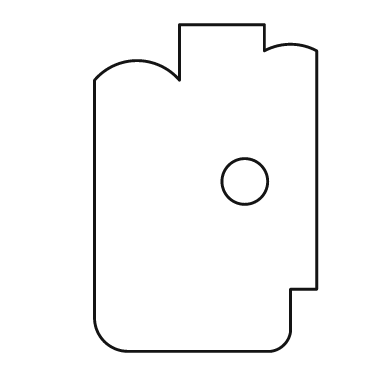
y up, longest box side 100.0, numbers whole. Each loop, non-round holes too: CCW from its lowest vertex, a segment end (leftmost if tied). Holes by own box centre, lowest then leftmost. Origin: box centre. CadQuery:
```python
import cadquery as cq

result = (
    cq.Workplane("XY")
    .moveTo(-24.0, -50.0)
    .lineTo(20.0, -50.0)
    .threePointArc((24.0, -48.0), (26.0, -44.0))
    .lineTo(26.0, -31.0)
    .lineTo(34.0, -31.0)
    .lineTo(34.0, 42.0)
    .threePointArc((26.0, 44.0), (18.0, 42.0))
    .lineTo(18.0, 50.0)
    .lineTo(-8.0, 50.0)
    .lineTo(-8.0, 33.0)
    .threePointArc((-21.0, 39.0), (-34.0, 33.0))
    .lineTo(-34.0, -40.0)
    .threePointArc((-31.0, -47.0), (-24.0, -50.0))
    .close()
    .moveTo(12.0, 2.0)
    .circle(7.0)
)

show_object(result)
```